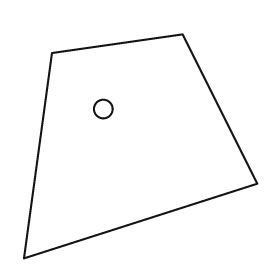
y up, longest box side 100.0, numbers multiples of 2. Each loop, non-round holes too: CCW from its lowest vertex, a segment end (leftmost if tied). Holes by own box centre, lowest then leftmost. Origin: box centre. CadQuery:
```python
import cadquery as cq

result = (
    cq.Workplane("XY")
    .moveTo(-50.0, -48.0)
    .lineTo(50.0, -16.0)
    .lineTo(18.0, 48.0)
    .lineTo(-38.0, 40.0)
    .close()
    .moveTo(-16.0, 16.0)
    .circle(4.0)
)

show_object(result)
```